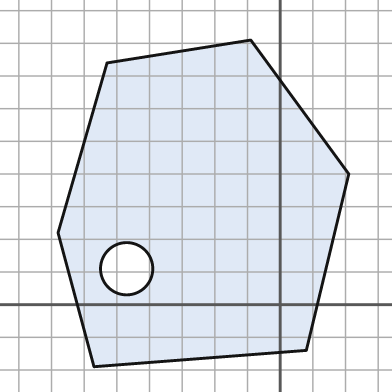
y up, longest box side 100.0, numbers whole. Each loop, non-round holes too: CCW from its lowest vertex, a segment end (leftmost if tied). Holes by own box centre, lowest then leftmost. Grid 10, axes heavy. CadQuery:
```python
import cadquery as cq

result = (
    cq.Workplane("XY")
    .moveTo(-57.0, -19.0)
    .lineTo(8.0, -14.0)
    .lineTo(21.0, 40.0)
    .lineTo(-9.0, 81.0)
    .lineTo(-53.0, 74.0)
    .lineTo(-68.0, 22.0)
    .close()
    .moveTo(-47.0, 11.0)
    .circle(8.0)
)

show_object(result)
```